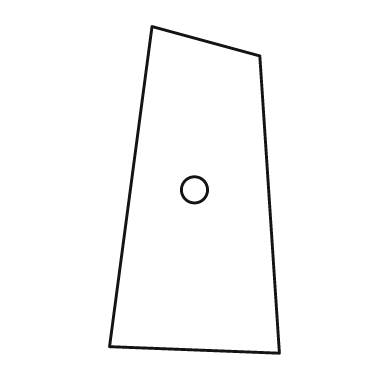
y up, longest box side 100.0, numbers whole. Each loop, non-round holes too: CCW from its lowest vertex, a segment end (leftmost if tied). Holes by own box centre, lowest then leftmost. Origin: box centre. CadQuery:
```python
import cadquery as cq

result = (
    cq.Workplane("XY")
    .moveTo(26.0, -50.0)
    .lineTo(20.0, 41.0)
    .lineTo(-13.0, 50.0)
    .lineTo(-26.0, -48.0)
    .close()
    .moveTo(0.0, 0.0)
    .circle(4.0)
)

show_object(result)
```